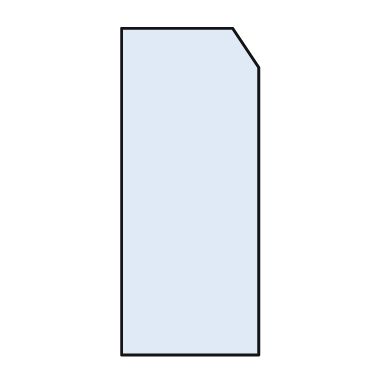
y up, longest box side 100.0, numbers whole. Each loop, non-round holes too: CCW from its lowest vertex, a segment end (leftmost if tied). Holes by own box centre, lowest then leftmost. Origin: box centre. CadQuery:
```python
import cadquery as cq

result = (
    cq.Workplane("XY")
    .moveTo(-21.0, -50.0)
    .lineTo(21.0, -50.0)
    .lineTo(21.0, 38.0)
    .lineTo(13.0, 50.0)
    .lineTo(-21.0, 50.0)
    .close()
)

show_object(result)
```